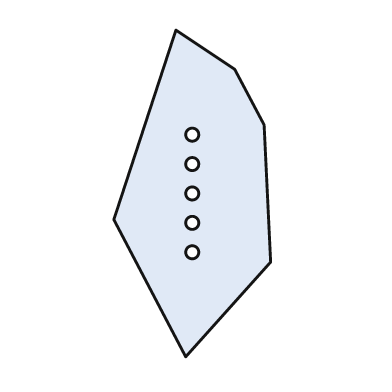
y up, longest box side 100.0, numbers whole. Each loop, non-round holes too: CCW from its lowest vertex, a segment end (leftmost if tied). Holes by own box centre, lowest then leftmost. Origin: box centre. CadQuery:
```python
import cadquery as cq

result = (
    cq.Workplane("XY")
    .moveTo(-2.0, -50.0)
    .lineTo(24.0, -21.0)
    .lineTo(22.0, 21.0)
    .lineTo(13.0, 38.0)
    .lineTo(-5.0, 50.0)
    .lineTo(-24.0, -8.0)
    .close()
    .moveTo(0.0, -18.0)
    .circle(2.0)
    .moveTo(0.0, -9.0)
    .circle(2.0)
    .moveTo(0.0, 0.0)
    .circle(2.0)
    .moveTo(0.0, 9.0)
    .circle(2.0)
    .moveTo(0.0, 18.0)
    .circle(2.0)
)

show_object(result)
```